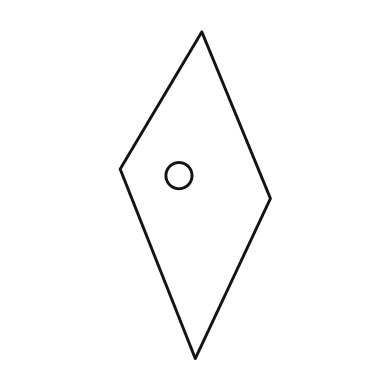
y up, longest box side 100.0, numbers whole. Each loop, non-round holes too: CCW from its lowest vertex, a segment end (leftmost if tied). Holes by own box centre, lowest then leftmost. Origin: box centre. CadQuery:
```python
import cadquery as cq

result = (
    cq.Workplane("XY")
    .moveTo(0.0, -50.0)
    .lineTo(23.0, -1.0)
    .lineTo(2.0, 50.0)
    .lineTo(-23.0, 8.0)
    .close()
    .moveTo(-5.0, 6.0)
    .circle(4.0)
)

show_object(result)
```